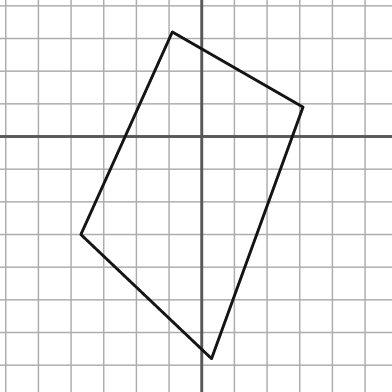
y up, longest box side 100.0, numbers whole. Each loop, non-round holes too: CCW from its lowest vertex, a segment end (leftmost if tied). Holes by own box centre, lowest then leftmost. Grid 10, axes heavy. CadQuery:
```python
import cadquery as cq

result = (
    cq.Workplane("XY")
    .moveTo(3.0, -68.0)
    .lineTo(31.0, 9.0)
    .lineTo(-9.0, 32.0)
    .lineTo(-37.0, -30.0)
    .close()
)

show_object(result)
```